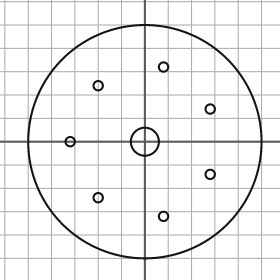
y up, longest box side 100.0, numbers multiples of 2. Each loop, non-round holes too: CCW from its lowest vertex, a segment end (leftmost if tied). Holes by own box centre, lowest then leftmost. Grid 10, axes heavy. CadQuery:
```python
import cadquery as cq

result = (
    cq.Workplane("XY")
    .moveTo(0.0, 0.0)
    .circle(50.0)
    .moveTo(8.0, -32.0)
    .circle(2.0)
    .moveTo(-20.0, -24.0)
    .circle(2.0)
    .moveTo(28.0, -14.0)
    .circle(2.0)
    .moveTo(-32.0, 0.0)
    .circle(2.0)
    .moveTo(0.0, 0.0)
    .circle(6.0)
    .moveTo(28.0, 14.0)
    .circle(2.0)
    .moveTo(-20.0, 24.0)
    .circle(2.0)
    .moveTo(8.0, 32.0)
    .circle(2.0)
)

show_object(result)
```